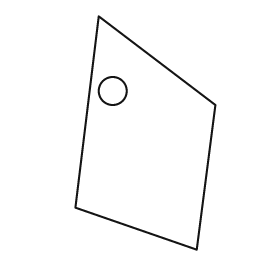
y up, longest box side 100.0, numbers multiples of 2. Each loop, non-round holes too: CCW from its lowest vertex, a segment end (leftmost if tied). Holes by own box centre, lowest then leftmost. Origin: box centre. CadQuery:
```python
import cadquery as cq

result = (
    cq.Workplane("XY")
    .moveTo(22.0, -50.0)
    .lineTo(30.0, 12.0)
    .lineTo(-20.0, 50.0)
    .lineTo(-30.0, -32.0)
    .close()
    .moveTo(-14.0, 18.0)
    .circle(6.0)
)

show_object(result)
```